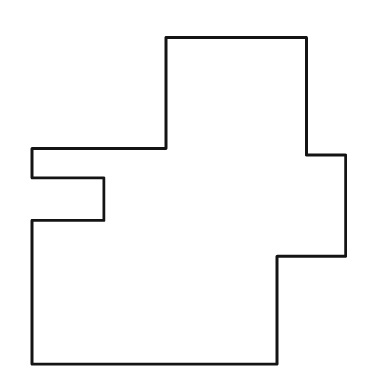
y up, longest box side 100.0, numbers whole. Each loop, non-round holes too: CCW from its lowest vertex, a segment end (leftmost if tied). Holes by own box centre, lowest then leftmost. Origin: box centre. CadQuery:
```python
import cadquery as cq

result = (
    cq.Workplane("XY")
    .moveTo(-48.0, -50.0)
    .lineTo(27.0, -50.0)
    .lineTo(27.0, -17.0)
    .lineTo(48.0, -17.0)
    .lineTo(48.0, 14.0)
    .lineTo(36.0, 14.0)
    .lineTo(36.0, 50.0)
    .lineTo(-7.0, 50.0)
    .lineTo(-7.0, 16.0)
    .lineTo(-48.0, 16.0)
    .lineTo(-48.0, 7.0)
    .lineTo(-26.0, 7.0)
    .lineTo(-26.0, -6.0)
    .lineTo(-48.0, -6.0)
    .close()
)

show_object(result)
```